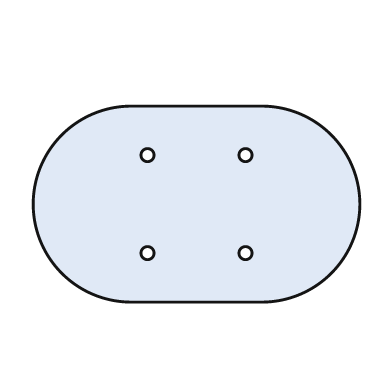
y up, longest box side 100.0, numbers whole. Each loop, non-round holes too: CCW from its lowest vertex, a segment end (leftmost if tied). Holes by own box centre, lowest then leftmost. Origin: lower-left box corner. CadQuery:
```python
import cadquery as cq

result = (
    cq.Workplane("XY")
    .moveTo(30.0, 0.0)
    .lineTo(70.0, 0.0)
    .threePointArc((100.0, 30.0), (70.0, 60.0))
    .lineTo(30.0, 60.0)
    .threePointArc((0.0, 30.0), (30.0, 0.0))
    .close()
    .moveTo(35.0, 15.0)
    .circle(2.0)
    .moveTo(65.0, 15.0)
    .circle(2.0)
    .moveTo(35.0, 45.0)
    .circle(2.0)
    .moveTo(65.0, 45.0)
    .circle(2.0)
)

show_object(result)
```